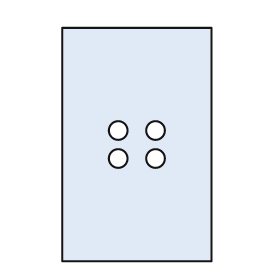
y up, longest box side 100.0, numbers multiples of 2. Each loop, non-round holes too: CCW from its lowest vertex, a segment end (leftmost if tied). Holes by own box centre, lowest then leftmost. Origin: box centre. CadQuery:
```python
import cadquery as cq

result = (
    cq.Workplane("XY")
    .moveTo(-32.0, -50.0)
    .lineTo(32.0, -50.0)
    .lineTo(32.0, 50.0)
    .lineTo(-32.0, 50.0)
    .close()
    .moveTo(-8.0, -6.0)
    .circle(4.0)
    .moveTo(8.0, -6.0)
    .circle(4.0)
    .moveTo(-8.0, 6.0)
    .circle(4.0)
    .moveTo(8.0, 6.0)
    .circle(4.0)
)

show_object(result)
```